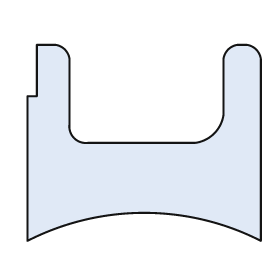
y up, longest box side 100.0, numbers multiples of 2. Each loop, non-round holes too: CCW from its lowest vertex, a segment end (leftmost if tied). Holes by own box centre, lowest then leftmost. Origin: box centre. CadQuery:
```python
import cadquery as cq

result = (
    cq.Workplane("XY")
    .moveTo(-50.0, -42.0)
    .threePointArc((0.0, -30.0), (50.0, -42.0))
    .lineTo(50.0, 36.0)
    .threePointArc((48.0, 40.0), (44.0, 42.0))
    .lineTo(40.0, 42.0)
    .threePointArc((36.0, 40.0), (34.0, 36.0))
    .lineTo(34.0, 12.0)
    .threePointArc((30.0, 4.0), (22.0, 0.0))
    .lineTo(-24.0, 0.0)
    .threePointArc((-30.0, 2.0), (-32.0, 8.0))
    .lineTo(-32.0, 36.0)
    .threePointArc((-34.0, 40.0), (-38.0, 42.0))
    .lineTo(-46.0, 42.0)
    .lineTo(-46.0, 20.0)
    .lineTo(-50.0, 20.0)
    .close()
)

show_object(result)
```